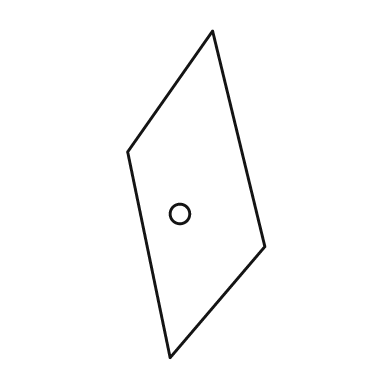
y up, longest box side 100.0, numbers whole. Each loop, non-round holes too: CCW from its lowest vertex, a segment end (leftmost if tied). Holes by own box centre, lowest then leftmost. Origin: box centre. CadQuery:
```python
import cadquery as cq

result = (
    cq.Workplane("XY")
    .moveTo(-8.0, -50.0)
    .lineTo(21.0, -16.0)
    .lineTo(5.0, 50.0)
    .lineTo(-21.0, 13.0)
    .close()
    .moveTo(-5.0, -6.0)
    .circle(3.0)
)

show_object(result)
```